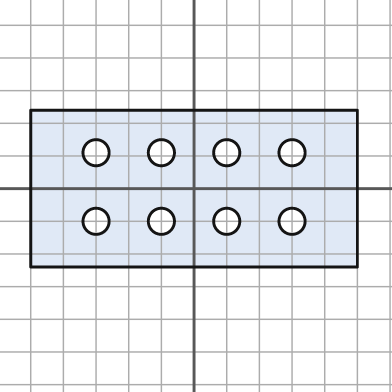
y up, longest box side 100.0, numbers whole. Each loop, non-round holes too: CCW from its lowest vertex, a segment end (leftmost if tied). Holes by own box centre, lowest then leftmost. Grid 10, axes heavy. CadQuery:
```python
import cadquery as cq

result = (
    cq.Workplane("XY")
    .moveTo(-50.0, -24.0)
    .lineTo(50.0, -24.0)
    .lineTo(50.0, 24.0)
    .lineTo(-50.0, 24.0)
    .close()
    .moveTo(-30.0, -10.0)
    .circle(4.0)
    .moveTo(-10.0, -10.0)
    .circle(4.0)
    .moveTo(10.0, -10.0)
    .circle(4.0)
    .moveTo(30.0, -10.0)
    .circle(4.0)
    .moveTo(-30.0, 11.0)
    .circle(4.0)
    .moveTo(-10.0, 11.0)
    .circle(4.0)
    .moveTo(10.0, 11.0)
    .circle(4.0)
    .moveTo(30.0, 11.0)
    .circle(4.0)
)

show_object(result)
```